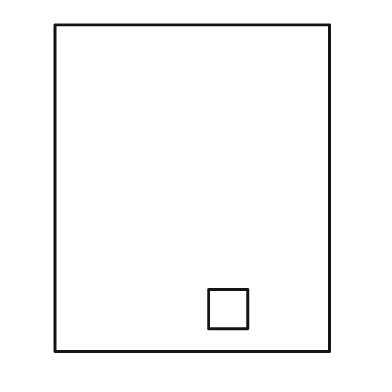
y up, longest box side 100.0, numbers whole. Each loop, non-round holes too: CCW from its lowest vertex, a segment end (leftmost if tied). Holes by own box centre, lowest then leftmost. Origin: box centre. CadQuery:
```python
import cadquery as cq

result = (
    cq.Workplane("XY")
    .moveTo(-42.0, -50.0)
    .lineTo(42.0, -50.0)
    .lineTo(42.0, 50.0)
    .lineTo(-42.0, 50.0)
    .close()
    .moveTo(5.0, -43.0)
    .lineTo(17.0, -43.0)
    .lineTo(17.0, -31.0)
    .lineTo(5.0, -31.0)
    .close()
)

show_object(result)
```